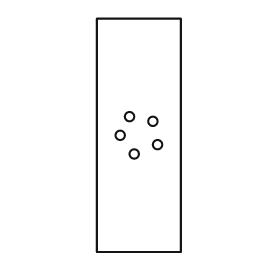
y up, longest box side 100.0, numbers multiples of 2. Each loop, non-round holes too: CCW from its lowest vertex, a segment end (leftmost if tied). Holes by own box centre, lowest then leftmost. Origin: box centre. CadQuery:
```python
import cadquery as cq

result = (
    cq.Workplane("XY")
    .moveTo(-18.0, -50.0)
    .lineTo(18.0, -50.0)
    .lineTo(18.0, 50.0)
    .lineTo(-18.0, 50.0)
    .close()
    .moveTo(-2.0, -8.0)
    .circle(2.0)
    .moveTo(8.0, -4.0)
    .circle(2.0)
    .moveTo(-8.0, 0.0)
    .circle(2.0)
    .moveTo(6.0, 6.0)
    .circle(2.0)
    .moveTo(-4.0, 8.0)
    .circle(2.0)
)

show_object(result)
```